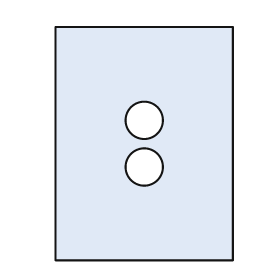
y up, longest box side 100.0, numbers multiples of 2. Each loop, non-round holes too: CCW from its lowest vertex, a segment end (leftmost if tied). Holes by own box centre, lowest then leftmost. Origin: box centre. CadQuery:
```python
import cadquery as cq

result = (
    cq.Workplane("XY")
    .moveTo(-38.0, -50.0)
    .lineTo(38.0, -50.0)
    .lineTo(38.0, 50.0)
    .lineTo(-38.0, 50.0)
    .close()
    .moveTo(0.0, -10.0)
    .circle(8.0)
    .moveTo(0.0, 10.0)
    .circle(8.0)
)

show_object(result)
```